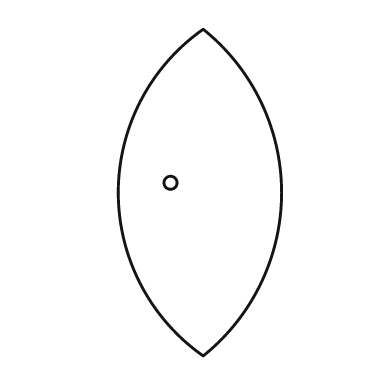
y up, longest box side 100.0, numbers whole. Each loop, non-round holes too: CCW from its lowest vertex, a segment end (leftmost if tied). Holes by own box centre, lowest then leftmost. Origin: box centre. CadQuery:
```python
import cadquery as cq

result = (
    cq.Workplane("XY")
    .moveTo(1.0, -50.0)
    .threePointArc((25.0, 0.0), (1.0, 50.0))
    .threePointArc((-25.0, 0.0), (1.0, -50.0))
    .close()
    .moveTo(-9.0, 3.0)
    .circle(2.0)
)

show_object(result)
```